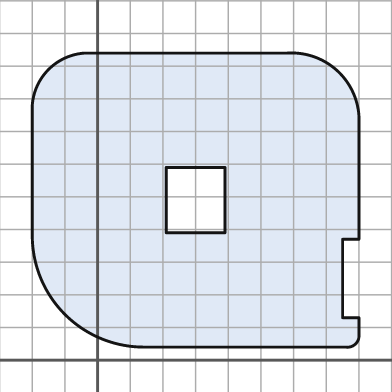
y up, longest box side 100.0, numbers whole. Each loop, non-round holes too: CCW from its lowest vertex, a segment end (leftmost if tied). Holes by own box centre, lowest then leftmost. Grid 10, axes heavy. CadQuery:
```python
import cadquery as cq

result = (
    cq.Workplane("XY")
    .moveTo(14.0, 4.0)
    .lineTo(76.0, 4.0)
    .threePointArc((79.0, 5.0), (80.0, 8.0))
    .lineTo(80.0, 13.0)
    .lineTo(75.0, 13.0)
    .lineTo(75.0, 37.0)
    .lineTo(80.0, 37.0)
    .lineTo(80.0, 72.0)
    .threePointArc((74.0, 88.0), (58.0, 94.0))
    .lineTo(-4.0, 94.0)
    .threePointArc((-15.0, 89.0), (-20.0, 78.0))
    .lineTo(-20.0, 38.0)
    .threePointArc((-10.0, 14.0), (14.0, 4.0))
    .close()
    .moveTo(21.0, 39.0)
    .lineTo(39.0, 39.0)
    .lineTo(39.0, 59.0)
    .lineTo(21.0, 59.0)
    .close()
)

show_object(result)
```